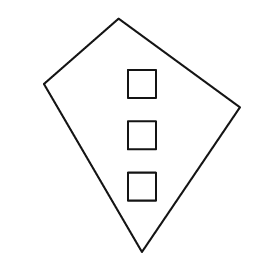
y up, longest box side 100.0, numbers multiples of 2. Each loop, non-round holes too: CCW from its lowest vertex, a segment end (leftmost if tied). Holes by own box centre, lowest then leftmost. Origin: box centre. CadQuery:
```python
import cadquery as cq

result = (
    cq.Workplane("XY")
    .moveTo(0.0, -50.0)
    .lineTo(42.0, 12.0)
    .lineTo(-10.0, 50.0)
    .lineTo(-42.0, 22.0)
    .close()
    .moveTo(-6.0, -28.0)
    .lineTo(6.0, -28.0)
    .lineTo(6.0, -16.0)
    .lineTo(-6.0, -16.0)
    .close()
    .moveTo(-6.0, -6.0)
    .lineTo(6.0, -6.0)
    .lineTo(6.0, 6.0)
    .lineTo(-6.0, 6.0)
    .close()
    .moveTo(-6.0, 16.0)
    .lineTo(6.0, 16.0)
    .lineTo(6.0, 28.0)
    .lineTo(-6.0, 28.0)
    .close()
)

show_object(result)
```